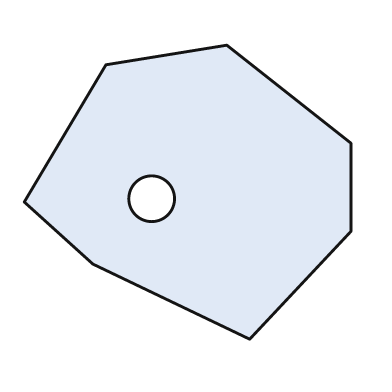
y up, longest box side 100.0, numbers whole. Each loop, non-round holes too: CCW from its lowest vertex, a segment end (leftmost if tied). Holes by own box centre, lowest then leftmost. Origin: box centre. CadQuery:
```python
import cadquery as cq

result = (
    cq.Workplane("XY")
    .moveTo(19.0, -45.0)
    .lineTo(50.0, -12.0)
    .lineTo(50.0, 15.0)
    .lineTo(12.0, 45.0)
    .lineTo(-25.0, 39.0)
    .lineTo(-50.0, -3.0)
    .lineTo(-29.0, -22.0)
    .close()
    .moveTo(-11.0, -2.0)
    .circle(7.0)
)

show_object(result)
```